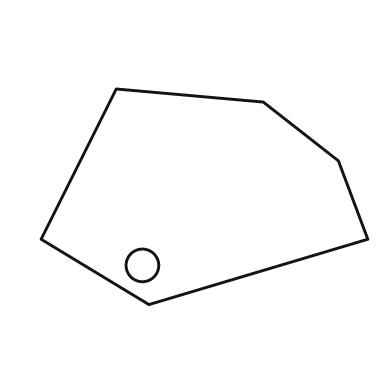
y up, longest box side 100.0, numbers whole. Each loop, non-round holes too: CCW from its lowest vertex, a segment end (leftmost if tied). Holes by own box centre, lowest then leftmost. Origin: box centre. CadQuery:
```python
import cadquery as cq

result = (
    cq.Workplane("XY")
    .moveTo(-17.0, -33.0)
    .lineTo(50.0, -13.0)
    .lineTo(41.0, 11.0)
    .lineTo(18.0, 29.0)
    .lineTo(-27.0, 33.0)
    .lineTo(-50.0, -13.0)
    .close()
    .moveTo(-19.0, -21.0)
    .circle(5.0)
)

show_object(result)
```